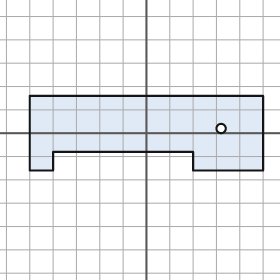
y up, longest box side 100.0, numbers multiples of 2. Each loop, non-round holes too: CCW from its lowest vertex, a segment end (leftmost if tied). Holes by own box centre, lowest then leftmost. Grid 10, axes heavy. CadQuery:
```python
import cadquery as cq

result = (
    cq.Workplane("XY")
    .moveTo(-50.0, -16.0)
    .lineTo(-40.0, -16.0)
    .lineTo(-40.0, -8.0)
    .lineTo(20.0, -8.0)
    .lineTo(20.0, -16.0)
    .lineTo(50.0, -16.0)
    .lineTo(50.0, 16.0)
    .lineTo(-50.0, 16.0)
    .close()
    .moveTo(32.0, 2.0)
    .circle(2.0)
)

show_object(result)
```